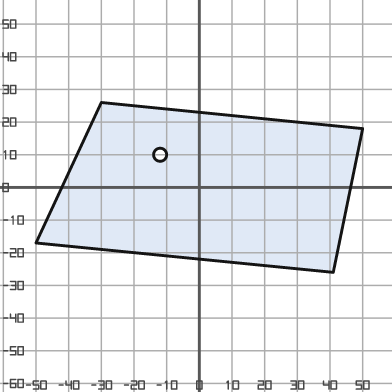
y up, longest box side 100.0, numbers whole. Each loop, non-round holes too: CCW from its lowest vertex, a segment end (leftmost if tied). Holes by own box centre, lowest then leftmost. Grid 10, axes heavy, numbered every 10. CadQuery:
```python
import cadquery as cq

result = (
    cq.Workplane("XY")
    .moveTo(41.0, -26.0)
    .lineTo(50.0, 18.0)
    .lineTo(-30.0, 26.0)
    .lineTo(-50.0, -17.0)
    .close()
    .moveTo(-12.0, 10.0)
    .circle(2.0)
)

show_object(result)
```